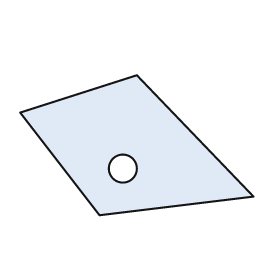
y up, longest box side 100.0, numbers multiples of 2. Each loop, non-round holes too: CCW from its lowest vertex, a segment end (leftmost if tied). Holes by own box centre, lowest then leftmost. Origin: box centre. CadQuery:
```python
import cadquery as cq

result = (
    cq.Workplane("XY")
    .moveTo(-16.0, -30.0)
    .lineTo(50.0, -22.0)
    .lineTo(0.0, 30.0)
    .lineTo(-50.0, 14.0)
    .close()
    .moveTo(-6.0, -10.0)
    .circle(6.0)
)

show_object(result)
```